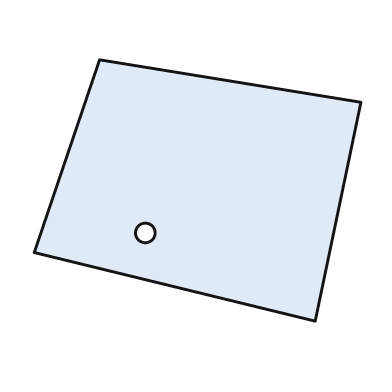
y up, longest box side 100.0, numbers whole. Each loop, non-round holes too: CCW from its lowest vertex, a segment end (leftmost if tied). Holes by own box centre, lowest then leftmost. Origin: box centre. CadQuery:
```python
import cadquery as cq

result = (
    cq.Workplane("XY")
    .moveTo(36.0, -40.0)
    .lineTo(50.0, 27.0)
    .lineTo(-30.0, 40.0)
    .lineTo(-50.0, -19.0)
    .close()
    .moveTo(-16.0, -13.0)
    .circle(3.0)
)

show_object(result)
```